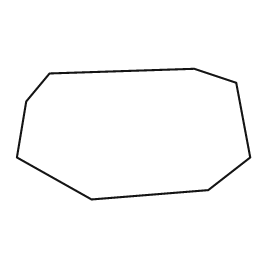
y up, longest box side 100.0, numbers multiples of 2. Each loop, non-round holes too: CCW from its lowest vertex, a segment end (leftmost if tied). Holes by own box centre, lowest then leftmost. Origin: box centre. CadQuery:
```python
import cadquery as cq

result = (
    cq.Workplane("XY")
    .moveTo(-18.0, -28.0)
    .lineTo(32.0, -24.0)
    .lineTo(50.0, -10.0)
    .lineTo(44.0, 22.0)
    .lineTo(26.0, 28.0)
    .lineTo(-36.0, 26.0)
    .lineTo(-46.0, 14.0)
    .lineTo(-50.0, -10.0)
    .close()
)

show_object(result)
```